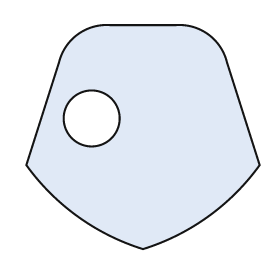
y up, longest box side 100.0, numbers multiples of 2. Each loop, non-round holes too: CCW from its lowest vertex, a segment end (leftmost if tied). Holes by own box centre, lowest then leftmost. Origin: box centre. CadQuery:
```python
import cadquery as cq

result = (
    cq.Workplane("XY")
    .moveTo(0.0, -48.0)
    .threePointArc((28.0, -34.0), (50.0, -12.0))
    .lineTo(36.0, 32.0)
    .threePointArc((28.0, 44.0), (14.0, 48.0))
    .lineTo(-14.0, 48.0)
    .threePointArc((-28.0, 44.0), (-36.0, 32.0))
    .lineTo(-50.0, -12.0)
    .threePointArc((-28.0, -34.0), (0.0, -48.0))
    .close()
    .moveTo(-22.0, 8.0)
    .circle(12.0)
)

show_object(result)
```